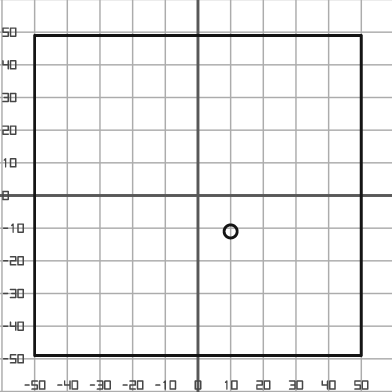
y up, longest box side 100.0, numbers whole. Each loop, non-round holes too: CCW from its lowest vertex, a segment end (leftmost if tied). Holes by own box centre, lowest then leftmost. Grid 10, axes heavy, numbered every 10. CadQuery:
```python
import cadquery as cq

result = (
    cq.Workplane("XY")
    .moveTo(-50.0, -49.0)
    .lineTo(50.0, -49.0)
    .lineTo(50.0, 49.0)
    .lineTo(-50.0, 49.0)
    .close()
    .moveTo(10.0, -11.0)
    .circle(2.0)
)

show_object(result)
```